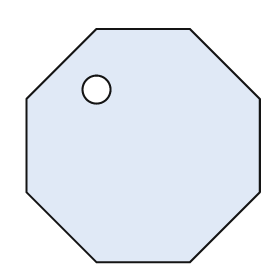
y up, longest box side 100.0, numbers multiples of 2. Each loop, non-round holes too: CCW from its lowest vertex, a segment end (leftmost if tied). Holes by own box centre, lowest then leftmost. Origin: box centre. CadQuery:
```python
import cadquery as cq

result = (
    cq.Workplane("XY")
    .moveTo(-20.0, -50.0)
    .lineTo(20.0, -50.0)
    .lineTo(50.0, -20.0)
    .lineTo(50.0, 20.0)
    .lineTo(20.0, 50.0)
    .lineTo(-20.0, 50.0)
    .lineTo(-50.0, 20.0)
    .lineTo(-50.0, -20.0)
    .close()
    .moveTo(-20.0, 24.0)
    .circle(6.0)
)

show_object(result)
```